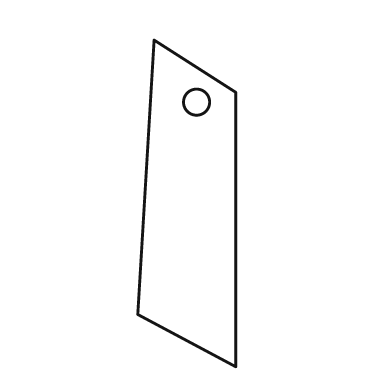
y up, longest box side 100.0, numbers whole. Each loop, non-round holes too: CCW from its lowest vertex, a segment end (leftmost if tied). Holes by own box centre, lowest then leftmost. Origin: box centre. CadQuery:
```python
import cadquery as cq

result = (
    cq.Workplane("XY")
    .moveTo(15.0, -50.0)
    .lineTo(15.0, 34.0)
    .lineTo(-10.0, 50.0)
    .lineTo(-15.0, -34.0)
    .close()
    .moveTo(3.0, 31.0)
    .circle(4.0)
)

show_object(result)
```